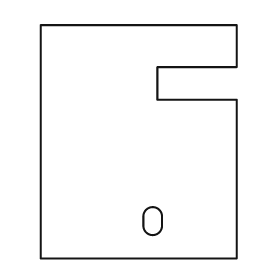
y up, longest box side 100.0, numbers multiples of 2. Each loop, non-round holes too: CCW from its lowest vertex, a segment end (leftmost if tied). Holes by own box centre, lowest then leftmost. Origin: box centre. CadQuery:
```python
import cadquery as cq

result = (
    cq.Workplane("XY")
    .moveTo(-42.0, -50.0)
    .lineTo(42.0, -50.0)
    .lineTo(42.0, 18.0)
    .lineTo(8.0, 18.0)
    .lineTo(8.0, 32.0)
    .lineTo(42.0, 32.0)
    .lineTo(42.0, 50.0)
    .lineTo(-42.0, 50.0)
    .close()
    .moveTo(2.0, -36.0)
    .threePointArc((6.0, -40.0), (10.0, -36.0))
    .lineTo(10.0, -32.0)
    .threePointArc((6.0, -28.0), (2.0, -32.0))
    .close()
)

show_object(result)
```